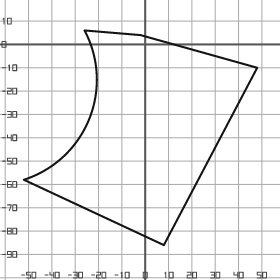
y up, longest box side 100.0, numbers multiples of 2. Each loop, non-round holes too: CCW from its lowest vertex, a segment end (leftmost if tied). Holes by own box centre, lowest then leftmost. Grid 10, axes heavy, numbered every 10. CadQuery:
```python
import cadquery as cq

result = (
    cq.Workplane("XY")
    .moveTo(8.0, -86.0)
    .lineTo(48.0, -10.0)
    .lineTo(-2.0, 4.0)
    .lineTo(-26.0, 6.0)
    .threePointArc((-24.0, -32.0), (-52.0, -58.0))
    .close()
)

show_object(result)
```